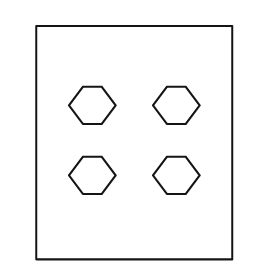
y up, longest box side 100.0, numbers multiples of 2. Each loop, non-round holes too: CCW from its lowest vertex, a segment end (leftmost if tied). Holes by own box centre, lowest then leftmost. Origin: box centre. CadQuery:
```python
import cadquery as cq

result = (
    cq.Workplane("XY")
    .moveTo(-42.0, -50.0)
    .lineTo(42.0, -50.0)
    .lineTo(42.0, 50.0)
    .lineTo(-42.0, 50.0)
    .close()
    .moveTo(-22.0, -22.0)
    .lineTo(-14.0, -22.0)
    .lineTo(-8.0, -14.0)
    .lineTo(-14.0, -6.0)
    .lineTo(-22.0, -6.0)
    .lineTo(-28.0, -14.0)
    .close()
    .moveTo(14.0, -22.0)
    .lineTo(22.0, -22.0)
    .lineTo(28.0, -14.0)
    .lineTo(22.0, -6.0)
    .lineTo(14.0, -6.0)
    .lineTo(8.0, -14.0)
    .close()
    .moveTo(-22.0, 8.0)
    .lineTo(-14.0, 8.0)
    .lineTo(-8.0, 16.0)
    .lineTo(-14.0, 24.0)
    .lineTo(-22.0, 24.0)
    .lineTo(-28.0, 16.0)
    .close()
    .moveTo(14.0, 8.0)
    .lineTo(22.0, 8.0)
    .lineTo(28.0, 16.0)
    .lineTo(22.0, 24.0)
    .lineTo(14.0, 24.0)
    .lineTo(8.0, 16.0)
    .close()
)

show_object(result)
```